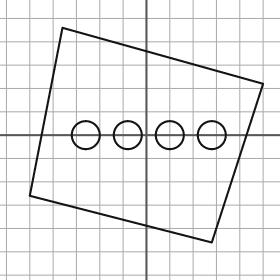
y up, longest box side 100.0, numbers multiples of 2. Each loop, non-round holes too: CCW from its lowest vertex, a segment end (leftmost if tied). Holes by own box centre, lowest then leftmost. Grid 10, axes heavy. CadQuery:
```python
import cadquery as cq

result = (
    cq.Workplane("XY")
    .moveTo(28.0, -46.0)
    .lineTo(50.0, 22.0)
    .lineTo(-36.0, 46.0)
    .lineTo(-50.0, -26.0)
    .close()
    .moveTo(-26.0, 0.0)
    .circle(6.0)
    .moveTo(-8.0, 0.0)
    .circle(6.0)
    .moveTo(10.0, 0.0)
    .circle(6.0)
    .moveTo(28.0, 0.0)
    .circle(6.0)
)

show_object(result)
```